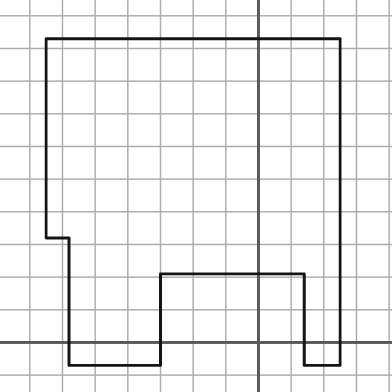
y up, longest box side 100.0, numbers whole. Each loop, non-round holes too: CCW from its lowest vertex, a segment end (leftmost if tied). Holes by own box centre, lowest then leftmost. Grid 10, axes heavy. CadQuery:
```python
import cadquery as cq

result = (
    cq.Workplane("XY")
    .moveTo(-58.0, -7.0)
    .lineTo(-30.0, -7.0)
    .lineTo(-30.0, 21.0)
    .lineTo(14.0, 21.0)
    .lineTo(14.0, -7.0)
    .lineTo(25.0, -7.0)
    .lineTo(25.0, 93.0)
    .lineTo(-65.0, 93.0)
    .lineTo(-65.0, 32.0)
    .lineTo(-58.0, 32.0)
    .close()
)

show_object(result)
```